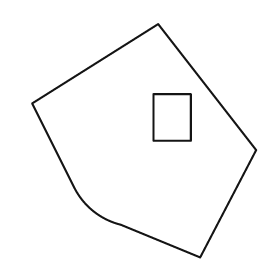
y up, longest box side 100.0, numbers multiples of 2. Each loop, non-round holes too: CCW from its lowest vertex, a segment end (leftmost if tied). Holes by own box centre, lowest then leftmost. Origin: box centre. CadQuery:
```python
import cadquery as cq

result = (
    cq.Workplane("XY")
    .moveTo(24.0, -50.0)
    .lineTo(48.0, -4.0)
    .lineTo(6.0, 50.0)
    .lineTo(-48.0, 16.0)
    .lineTo(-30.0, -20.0)
    .threePointArc((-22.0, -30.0), (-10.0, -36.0))
    .close()
    .moveTo(4.0, 0.0)
    .lineTo(20.0, 0.0)
    .lineTo(20.0, 20.0)
    .lineTo(4.0, 20.0)
    .close()
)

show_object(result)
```